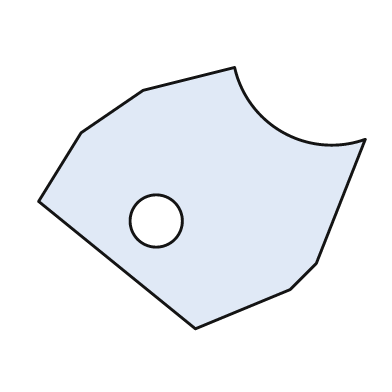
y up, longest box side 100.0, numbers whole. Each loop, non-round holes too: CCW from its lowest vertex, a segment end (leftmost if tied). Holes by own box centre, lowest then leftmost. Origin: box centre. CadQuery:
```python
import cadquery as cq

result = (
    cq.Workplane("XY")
    .moveTo(-2.0, -40.0)
    .lineTo(27.0, -28.0)
    .lineTo(35.0, -20.0)
    .lineTo(50.0, 18.0)
    .threePointArc((25.0, 20.0), (10.0, 40.0))
    .lineTo(-18.0, 33.0)
    .lineTo(-37.0, 20.0)
    .lineTo(-50.0, -1.0)
    .close()
    .moveTo(-14.0, -7.0)
    .circle(8.0)
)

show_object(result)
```